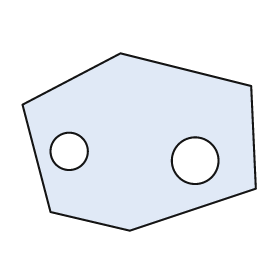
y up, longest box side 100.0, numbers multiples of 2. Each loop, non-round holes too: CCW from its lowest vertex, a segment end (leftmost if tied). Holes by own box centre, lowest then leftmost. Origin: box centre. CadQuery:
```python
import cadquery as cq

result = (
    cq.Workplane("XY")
    .moveTo(-4.0, -38.0)
    .lineTo(50.0, -20.0)
    .lineTo(48.0, 24.0)
    .lineTo(-8.0, 38.0)
    .lineTo(-50.0, 16.0)
    .lineTo(-38.0, -30.0)
    .close()
    .moveTo(24.0, -8.0)
    .circle(10.0)
    .moveTo(-30.0, -4.0)
    .circle(8.0)
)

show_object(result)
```